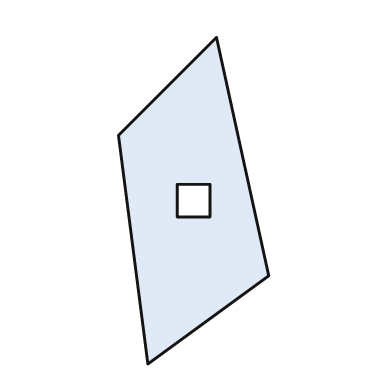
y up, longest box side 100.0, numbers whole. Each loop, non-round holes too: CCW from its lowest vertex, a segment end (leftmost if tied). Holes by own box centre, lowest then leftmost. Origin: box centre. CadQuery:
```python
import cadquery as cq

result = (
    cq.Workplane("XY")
    .moveTo(-14.0, -50.0)
    .lineTo(23.0, -23.0)
    .lineTo(7.0, 50.0)
    .lineTo(-23.0, 20.0)
    .close()
    .moveTo(-5.0, -5.0)
    .lineTo(5.0, -5.0)
    .lineTo(5.0, 5.0)
    .lineTo(-5.0, 5.0)
    .close()
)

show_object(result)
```